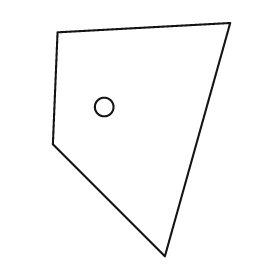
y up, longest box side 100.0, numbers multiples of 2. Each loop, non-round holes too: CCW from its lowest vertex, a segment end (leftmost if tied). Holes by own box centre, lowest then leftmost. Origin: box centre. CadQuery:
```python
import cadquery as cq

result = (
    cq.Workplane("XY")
    .moveTo(10.0, -50.0)
    .lineTo(38.0, 50.0)
    .lineTo(-36.0, 46.0)
    .lineTo(-38.0, -2.0)
    .close()
    .moveTo(-16.0, 14.0)
    .circle(4.0)
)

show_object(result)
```